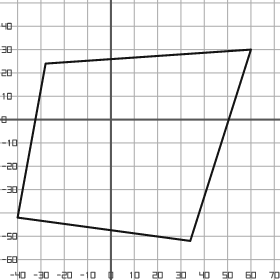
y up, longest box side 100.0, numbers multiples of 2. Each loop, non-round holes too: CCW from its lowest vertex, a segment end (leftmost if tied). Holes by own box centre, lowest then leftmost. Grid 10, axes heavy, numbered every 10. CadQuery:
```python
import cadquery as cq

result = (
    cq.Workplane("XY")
    .moveTo(34.0, -52.0)
    .lineTo(60.0, 30.0)
    .lineTo(-28.0, 24.0)
    .lineTo(-40.0, -42.0)
    .close()
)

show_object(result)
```